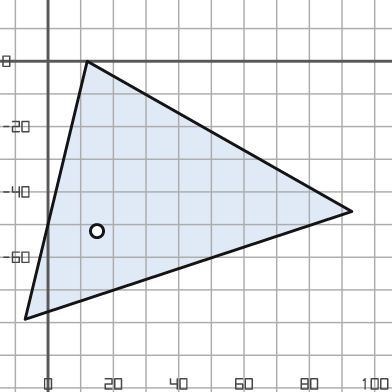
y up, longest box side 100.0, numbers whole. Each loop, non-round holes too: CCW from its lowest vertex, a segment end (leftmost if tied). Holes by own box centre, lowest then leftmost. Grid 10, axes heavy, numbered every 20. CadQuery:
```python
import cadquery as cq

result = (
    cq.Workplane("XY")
    .moveTo(-7.0, -79.0)
    .lineTo(93.0, -46.0)
    .lineTo(12.0, 0.0)
    .close()
    .moveTo(15.0, -52.0)
    .circle(2.0)
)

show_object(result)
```